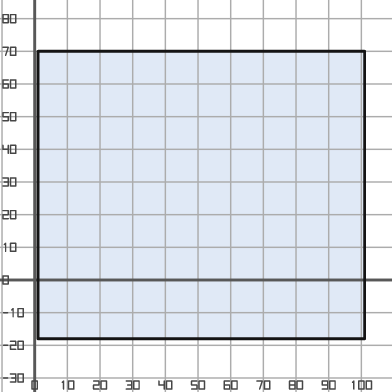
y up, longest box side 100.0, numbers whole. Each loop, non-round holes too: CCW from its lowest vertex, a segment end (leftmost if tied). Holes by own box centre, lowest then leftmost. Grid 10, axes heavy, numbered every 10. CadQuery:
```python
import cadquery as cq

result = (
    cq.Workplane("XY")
    .moveTo(1.0, -18.0)
    .lineTo(101.0, -18.0)
    .lineTo(101.0, 70.0)
    .lineTo(1.0, 70.0)
    .close()
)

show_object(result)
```